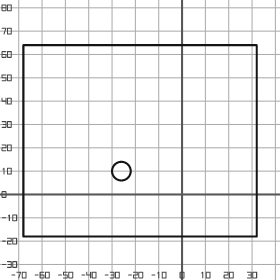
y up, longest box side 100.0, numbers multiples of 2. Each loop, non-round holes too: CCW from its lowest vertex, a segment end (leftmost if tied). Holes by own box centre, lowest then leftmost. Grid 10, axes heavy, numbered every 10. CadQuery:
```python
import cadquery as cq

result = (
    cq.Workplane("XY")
    .moveTo(-68.0, -18.0)
    .lineTo(32.0, -18.0)
    .lineTo(32.0, 64.0)
    .lineTo(-68.0, 64.0)
    .close()
    .moveTo(-26.0, 10.0)
    .circle(4.0)
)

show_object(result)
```